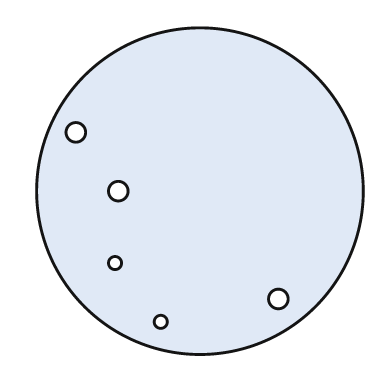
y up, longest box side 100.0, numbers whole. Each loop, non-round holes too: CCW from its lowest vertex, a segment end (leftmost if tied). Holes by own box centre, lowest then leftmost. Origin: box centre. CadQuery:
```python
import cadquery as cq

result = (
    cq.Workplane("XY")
    .moveTo(0.0, 0.0)
    .circle(50.0)
    .moveTo(-12.0, -40.0)
    .circle(2.0)
    .moveTo(24.0, -33.0)
    .circle(3.0)
    .moveTo(-26.0, -22.0)
    .circle(2.0)
    .moveTo(-25.0, 0.0)
    .circle(3.0)
    .moveTo(-38.0, 18.0)
    .circle(3.0)
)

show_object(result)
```